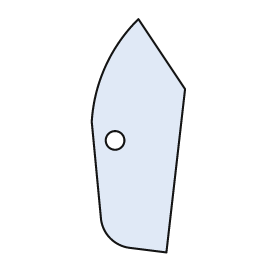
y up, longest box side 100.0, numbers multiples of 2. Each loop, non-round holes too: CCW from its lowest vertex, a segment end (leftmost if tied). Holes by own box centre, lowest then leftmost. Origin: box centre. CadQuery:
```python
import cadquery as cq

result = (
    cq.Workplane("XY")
    .moveTo(12.0, -50.0)
    .lineTo(20.0, 20.0)
    .lineTo(0.0, 50.0)
    .threePointArc((-14.0, 30.0), (-20.0, 6.0))
    .lineTo(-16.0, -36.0)
    .threePointArc((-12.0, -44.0), (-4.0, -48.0))
    .close()
    .moveTo(-10.0, -2.0)
    .circle(4.0)
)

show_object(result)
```